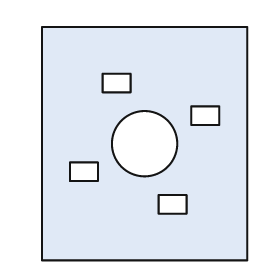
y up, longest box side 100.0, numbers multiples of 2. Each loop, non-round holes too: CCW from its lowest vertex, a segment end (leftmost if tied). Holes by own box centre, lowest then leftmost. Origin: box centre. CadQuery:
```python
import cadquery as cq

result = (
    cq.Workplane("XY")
    .moveTo(-44.0, -50.0)
    .lineTo(44.0, -50.0)
    .lineTo(44.0, 50.0)
    .lineTo(-44.0, 50.0)
    .close()
    .moveTo(6.0, -30.0)
    .lineTo(18.0, -30.0)
    .lineTo(18.0, -22.0)
    .lineTo(6.0, -22.0)
    .close()
    .moveTo(-32.0, -16.0)
    .lineTo(-20.0, -16.0)
    .lineTo(-20.0, -8.0)
    .lineTo(-32.0, -8.0)
    .close()
    .moveTo(0.0, 0.0)
    .circle(14.0)
    .moveTo(20.0, 8.0)
    .lineTo(32.0, 8.0)
    .lineTo(32.0, 16.0)
    .lineTo(20.0, 16.0)
    .close()
    .moveTo(-18.0, 22.0)
    .lineTo(-6.0, 22.0)
    .lineTo(-6.0, 30.0)
    .lineTo(-18.0, 30.0)
    .close()
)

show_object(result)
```